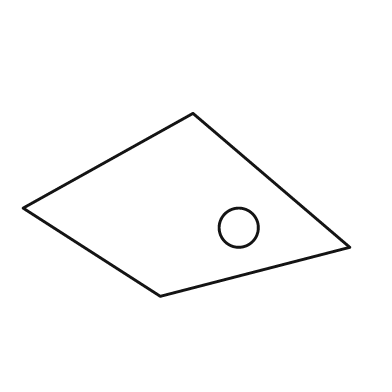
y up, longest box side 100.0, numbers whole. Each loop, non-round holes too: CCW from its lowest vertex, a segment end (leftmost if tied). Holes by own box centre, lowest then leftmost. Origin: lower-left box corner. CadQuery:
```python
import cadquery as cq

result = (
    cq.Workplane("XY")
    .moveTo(42.0, 0.0)
    .lineTo(100.0, 15.0)
    .lineTo(52.0, 56.0)
    .lineTo(0.0, 27.0)
    .close()
    .moveTo(66.0, 21.0)
    .circle(6.0)
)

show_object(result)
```